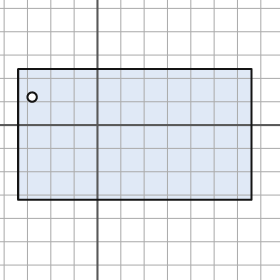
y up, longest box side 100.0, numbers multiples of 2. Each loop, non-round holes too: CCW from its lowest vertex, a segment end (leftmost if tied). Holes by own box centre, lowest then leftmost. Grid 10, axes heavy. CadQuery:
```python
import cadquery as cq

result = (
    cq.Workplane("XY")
    .moveTo(-34.0, -32.0)
    .lineTo(66.0, -32.0)
    .lineTo(66.0, 24.0)
    .lineTo(-34.0, 24.0)
    .close()
    .moveTo(-28.0, 12.0)
    .circle(2.0)
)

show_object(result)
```